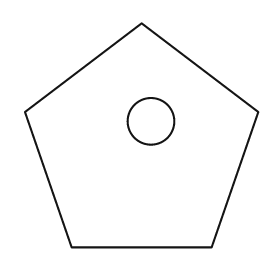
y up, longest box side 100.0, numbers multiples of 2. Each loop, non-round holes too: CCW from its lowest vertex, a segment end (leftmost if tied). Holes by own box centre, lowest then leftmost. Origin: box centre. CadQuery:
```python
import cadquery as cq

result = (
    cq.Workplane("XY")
    .moveTo(-30.0, -48.0)
    .lineTo(30.0, -48.0)
    .lineTo(50.0, 10.0)
    .lineTo(0.0, 48.0)
    .lineTo(-50.0, 10.0)
    .close()
    .moveTo(4.0, 6.0)
    .circle(10.0)
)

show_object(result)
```